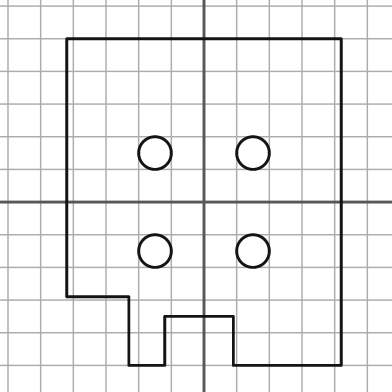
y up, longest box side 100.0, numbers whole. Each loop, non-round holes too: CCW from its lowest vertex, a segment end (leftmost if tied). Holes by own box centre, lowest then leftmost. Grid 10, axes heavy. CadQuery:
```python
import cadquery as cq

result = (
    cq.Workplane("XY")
    .moveTo(-23.0, -50.0)
    .lineTo(-12.0, -50.0)
    .lineTo(-12.0, -35.0)
    .lineTo(9.0, -35.0)
    .lineTo(9.0, -50.0)
    .lineTo(42.0, -50.0)
    .lineTo(42.0, 50.0)
    .lineTo(-42.0, 50.0)
    .lineTo(-42.0, -29.0)
    .lineTo(-23.0, -29.0)
    .close()
    .moveTo(-15.0, -15.0)
    .circle(5.0)
    .moveTo(15.0, -15.0)
    .circle(5.0)
    .moveTo(-15.0, 15.0)
    .circle(5.0)
    .moveTo(15.0, 15.0)
    .circle(5.0)
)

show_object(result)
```